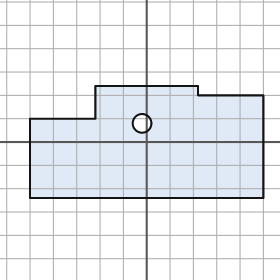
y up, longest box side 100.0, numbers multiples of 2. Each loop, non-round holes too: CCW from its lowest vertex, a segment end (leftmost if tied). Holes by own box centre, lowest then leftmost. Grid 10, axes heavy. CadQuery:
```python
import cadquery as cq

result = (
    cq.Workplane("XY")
    .moveTo(-50.0, -24.0)
    .lineTo(50.0, -24.0)
    .lineTo(50.0, 20.0)
    .lineTo(22.0, 20.0)
    .lineTo(22.0, 24.0)
    .lineTo(-22.0, 24.0)
    .lineTo(-22.0, 10.0)
    .lineTo(-50.0, 10.0)
    .close()
    .moveTo(-2.0, 8.0)
    .circle(4.0)
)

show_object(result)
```